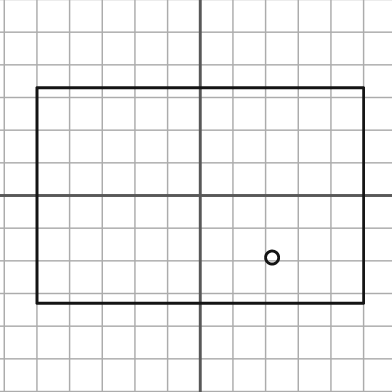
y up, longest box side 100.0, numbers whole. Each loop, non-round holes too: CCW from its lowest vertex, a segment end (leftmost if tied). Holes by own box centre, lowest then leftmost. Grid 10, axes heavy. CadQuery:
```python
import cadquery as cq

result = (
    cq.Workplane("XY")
    .moveTo(-50.0, -33.0)
    .lineTo(50.0, -33.0)
    .lineTo(50.0, 33.0)
    .lineTo(-50.0, 33.0)
    .close()
    .moveTo(22.0, -19.0)
    .circle(2.0)
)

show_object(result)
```